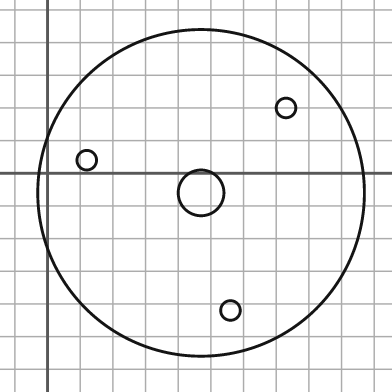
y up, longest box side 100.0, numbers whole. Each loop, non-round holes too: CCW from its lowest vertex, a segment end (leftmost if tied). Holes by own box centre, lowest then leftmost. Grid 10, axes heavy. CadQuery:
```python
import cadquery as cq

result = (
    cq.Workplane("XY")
    .moveTo(47.0, -6.0)
    .circle(50.0)
    .moveTo(56.0, -42.0)
    .circle(3.0)
    .moveTo(47.0, -6.0)
    .circle(7.0)
    .moveTo(12.0, 4.0)
    .circle(3.0)
    .moveTo(73.0, 20.0)
    .circle(3.0)
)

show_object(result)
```